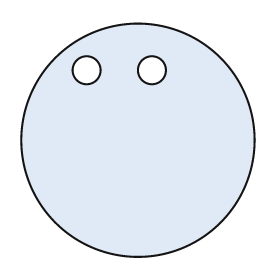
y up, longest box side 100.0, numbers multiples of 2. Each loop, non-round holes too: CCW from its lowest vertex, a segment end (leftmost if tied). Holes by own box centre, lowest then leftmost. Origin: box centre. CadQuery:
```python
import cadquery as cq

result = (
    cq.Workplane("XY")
    .moveTo(0.0, 0.0)
    .circle(50.0)
    .moveTo(-22.0, 30.0)
    .circle(6.0)
    .moveTo(6.0, 30.0)
    .circle(6.0)
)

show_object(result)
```